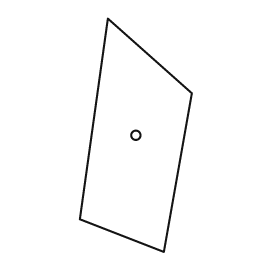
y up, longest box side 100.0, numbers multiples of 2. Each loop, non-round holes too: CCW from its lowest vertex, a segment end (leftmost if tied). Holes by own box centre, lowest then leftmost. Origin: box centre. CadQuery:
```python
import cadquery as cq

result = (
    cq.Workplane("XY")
    .moveTo(12.0, -50.0)
    .lineTo(24.0, 18.0)
    .lineTo(-12.0, 50.0)
    .lineTo(-24.0, -36.0)
    .close()
    .moveTo(0.0, 0.0)
    .circle(2.0)
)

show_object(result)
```